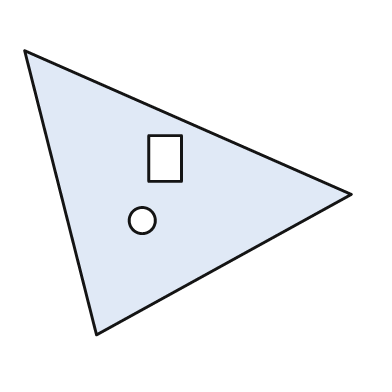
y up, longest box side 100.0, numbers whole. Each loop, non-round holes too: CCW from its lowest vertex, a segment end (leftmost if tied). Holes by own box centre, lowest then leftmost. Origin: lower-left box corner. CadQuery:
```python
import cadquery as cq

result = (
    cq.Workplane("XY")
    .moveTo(22.0, 0.0)
    .lineTo(100.0, 43.0)
    .lineTo(0.0, 87.0)
    .close()
    .moveTo(36.0, 35.0)
    .circle(4.0)
    .moveTo(38.0, 47.0)
    .lineTo(48.0, 47.0)
    .lineTo(48.0, 61.0)
    .lineTo(38.0, 61.0)
    .close()
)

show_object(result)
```